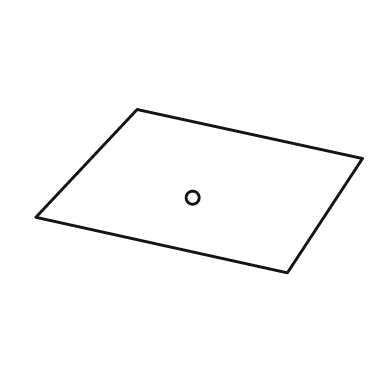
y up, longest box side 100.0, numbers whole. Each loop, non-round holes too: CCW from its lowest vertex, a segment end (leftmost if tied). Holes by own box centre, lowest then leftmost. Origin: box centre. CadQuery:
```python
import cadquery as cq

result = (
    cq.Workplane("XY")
    .moveTo(27.0, -25.0)
    .lineTo(50.0, 10.0)
    .lineTo(-19.0, 25.0)
    .lineTo(-50.0, -8.0)
    .close()
    .moveTo(-2.0, -2.0)
    .circle(2.0)
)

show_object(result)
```